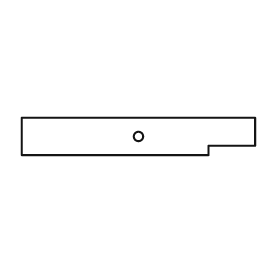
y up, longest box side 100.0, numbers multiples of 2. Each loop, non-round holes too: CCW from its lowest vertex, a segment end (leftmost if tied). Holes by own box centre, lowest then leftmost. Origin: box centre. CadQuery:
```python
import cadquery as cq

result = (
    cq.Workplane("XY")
    .moveTo(-50.0, -8.0)
    .lineTo(30.0, -8.0)
    .lineTo(30.0, -4.0)
    .lineTo(50.0, -4.0)
    .lineTo(50.0, 8.0)
    .lineTo(-50.0, 8.0)
    .close()
    .moveTo(0.0, 0.0)
    .circle(2.0)
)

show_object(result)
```